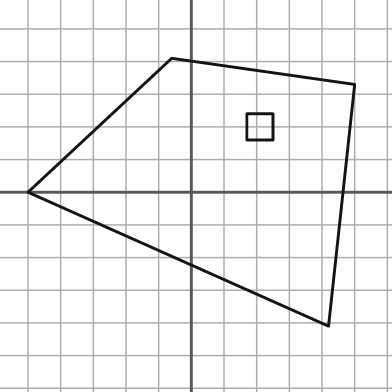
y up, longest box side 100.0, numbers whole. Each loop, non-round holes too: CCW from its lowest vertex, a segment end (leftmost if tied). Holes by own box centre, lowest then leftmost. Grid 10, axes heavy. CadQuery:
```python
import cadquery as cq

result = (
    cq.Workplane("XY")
    .moveTo(42.0, -41.0)
    .lineTo(50.0, 33.0)
    .lineTo(-6.0, 41.0)
    .lineTo(-50.0, 0.0)
    .close()
    .moveTo(17.0, 16.0)
    .lineTo(25.0, 16.0)
    .lineTo(25.0, 24.0)
    .lineTo(17.0, 24.0)
    .close()
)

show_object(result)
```